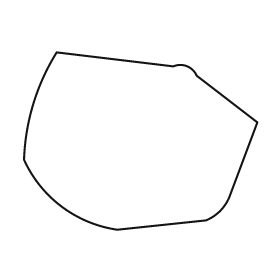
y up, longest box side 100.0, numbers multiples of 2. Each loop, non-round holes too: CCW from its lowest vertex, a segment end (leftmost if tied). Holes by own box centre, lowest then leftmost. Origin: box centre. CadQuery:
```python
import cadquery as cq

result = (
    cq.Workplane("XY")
    .moveTo(-10.0, -38.0)
    .lineTo(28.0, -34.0)
    .threePointArc((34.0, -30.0), (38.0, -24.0))
    .lineTo(50.0, 8.0)
    .lineTo(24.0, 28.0)
    .threePointArc((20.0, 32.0), (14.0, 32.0))
    .lineTo(-36.0, 38.0)
    .threePointArc((-46.0, 16.0), (-50.0, -8.0))
    .threePointArc((-34.0, -28.0), (-10.0, -38.0))
    .close()
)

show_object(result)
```